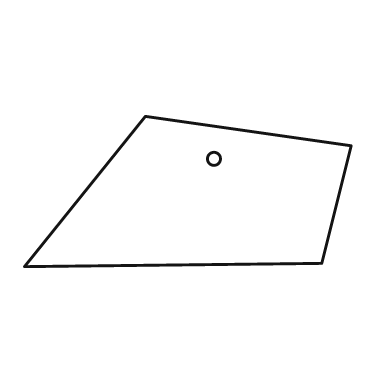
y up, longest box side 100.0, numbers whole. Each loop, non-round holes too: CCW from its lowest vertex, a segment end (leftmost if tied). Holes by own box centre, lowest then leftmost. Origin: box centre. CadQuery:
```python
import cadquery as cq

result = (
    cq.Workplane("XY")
    .moveTo(-50.0, -23.0)
    .lineTo(41.0, -22.0)
    .lineTo(50.0, 14.0)
    .lineTo(-13.0, 23.0)
    .close()
    .moveTo(8.0, 10.0)
    .circle(2.0)
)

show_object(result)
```